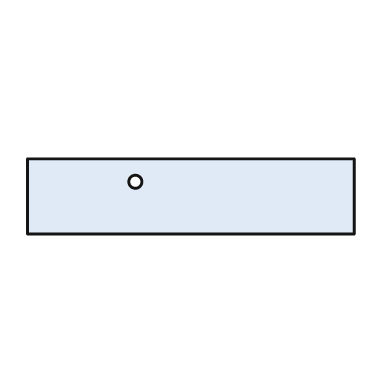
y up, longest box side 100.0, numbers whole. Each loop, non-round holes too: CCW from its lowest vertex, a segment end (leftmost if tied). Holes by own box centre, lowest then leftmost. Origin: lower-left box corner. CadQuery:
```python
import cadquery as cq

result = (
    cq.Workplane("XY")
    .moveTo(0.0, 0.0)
    .lineTo(100.0, 0.0)
    .lineTo(100.0, 23.0)
    .lineTo(0.0, 23.0)
    .close()
    .moveTo(33.0, 16.0)
    .circle(2.0)
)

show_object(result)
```